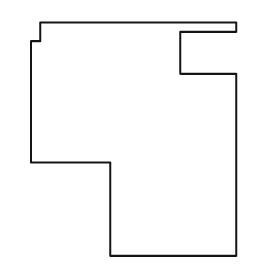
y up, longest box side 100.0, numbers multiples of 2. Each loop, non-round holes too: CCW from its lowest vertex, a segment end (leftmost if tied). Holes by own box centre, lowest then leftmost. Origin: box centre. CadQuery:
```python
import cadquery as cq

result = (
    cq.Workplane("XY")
    .moveTo(-10.0, -50.0)
    .lineTo(44.0, -50.0)
    .lineTo(44.0, 28.0)
    .lineTo(20.0, 28.0)
    .lineTo(20.0, 46.0)
    .lineTo(44.0, 46.0)
    .lineTo(44.0, 50.0)
    .lineTo(-40.0, 50.0)
    .lineTo(-40.0, 42.0)
    .lineTo(-44.0, 42.0)
    .lineTo(-44.0, -10.0)
    .lineTo(-10.0, -10.0)
    .close()
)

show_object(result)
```